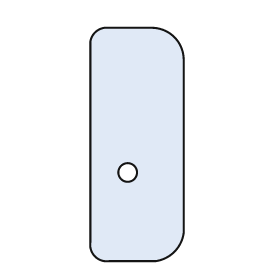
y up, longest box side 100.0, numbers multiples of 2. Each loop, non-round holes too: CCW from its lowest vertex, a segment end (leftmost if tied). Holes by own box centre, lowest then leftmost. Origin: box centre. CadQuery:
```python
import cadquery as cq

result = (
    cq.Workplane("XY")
    .moveTo(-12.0, -50.0)
    .lineTo(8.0, -50.0)
    .threePointArc((16.0, -46.0), (20.0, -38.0))
    .lineTo(20.0, 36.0)
    .threePointArc((16.0, 46.0), (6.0, 50.0))
    .lineTo(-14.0, 50.0)
    .threePointArc((-18.0, 48.0), (-20.0, 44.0))
    .lineTo(-20.0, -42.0)
    .threePointArc((-18.0, -48.0), (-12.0, -50.0))
    .close()
    .moveTo(-4.0, -12.0)
    .circle(4.0)
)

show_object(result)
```